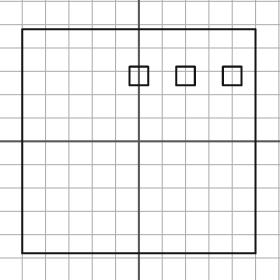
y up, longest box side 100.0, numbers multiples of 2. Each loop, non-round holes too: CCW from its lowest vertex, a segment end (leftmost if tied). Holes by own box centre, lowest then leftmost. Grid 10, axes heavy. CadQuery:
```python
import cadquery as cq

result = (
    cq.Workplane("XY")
    .moveTo(-50.0, -48.0)
    .lineTo(50.0, -48.0)
    .lineTo(50.0, 48.0)
    .lineTo(-50.0, 48.0)
    .close()
    .moveTo(-4.0, 24.0)
    .lineTo(4.0, 24.0)
    .lineTo(4.0, 32.0)
    .lineTo(-4.0, 32.0)
    .close()
    .moveTo(16.0, 24.0)
    .lineTo(24.0, 24.0)
    .lineTo(24.0, 32.0)
    .lineTo(16.0, 32.0)
    .close()
    .moveTo(36.0, 24.0)
    .lineTo(44.0, 24.0)
    .lineTo(44.0, 32.0)
    .lineTo(36.0, 32.0)
    .close()
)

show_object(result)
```